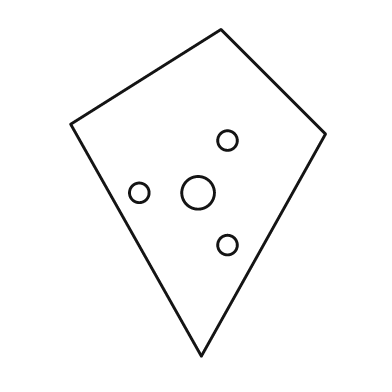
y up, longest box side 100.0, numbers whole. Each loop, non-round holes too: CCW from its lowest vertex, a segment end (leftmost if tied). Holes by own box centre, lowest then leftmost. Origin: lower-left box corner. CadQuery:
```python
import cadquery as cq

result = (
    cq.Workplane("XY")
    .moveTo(40.0, 0.0)
    .lineTo(78.0, 68.0)
    .lineTo(46.0, 100.0)
    .lineTo(0.0, 71.0)
    .close()
    .moveTo(48.0, 34.0)
    .circle(3.0)
    .moveTo(21.0, 50.0)
    .circle(3.0)
    .moveTo(39.0, 50.0)
    .circle(5.0)
    .moveTo(48.0, 66.0)
    .circle(3.0)
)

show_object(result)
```